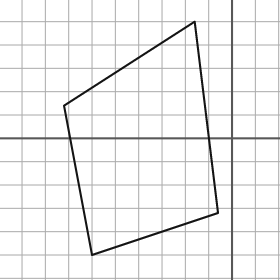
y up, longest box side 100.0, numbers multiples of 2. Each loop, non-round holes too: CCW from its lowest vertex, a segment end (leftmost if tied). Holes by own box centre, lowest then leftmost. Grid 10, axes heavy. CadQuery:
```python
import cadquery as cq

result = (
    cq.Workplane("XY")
    .moveTo(-60.0, -50.0)
    .lineTo(-6.0, -32.0)
    .lineTo(-16.0, 50.0)
    .lineTo(-72.0, 14.0)
    .close()
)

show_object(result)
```